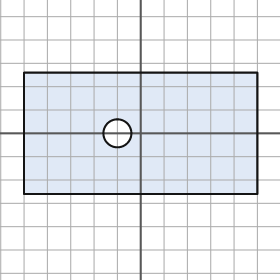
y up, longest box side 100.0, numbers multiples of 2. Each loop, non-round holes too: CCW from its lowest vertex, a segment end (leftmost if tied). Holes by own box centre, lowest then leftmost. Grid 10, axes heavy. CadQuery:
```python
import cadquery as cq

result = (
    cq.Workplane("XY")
    .moveTo(-50.0, -26.0)
    .lineTo(50.0, -26.0)
    .lineTo(50.0, 26.0)
    .lineTo(-50.0, 26.0)
    .close()
    .moveTo(-10.0, 0.0)
    .circle(6.0)
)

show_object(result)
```